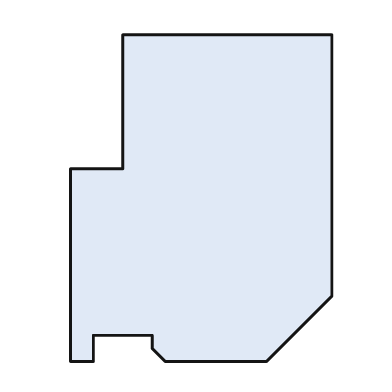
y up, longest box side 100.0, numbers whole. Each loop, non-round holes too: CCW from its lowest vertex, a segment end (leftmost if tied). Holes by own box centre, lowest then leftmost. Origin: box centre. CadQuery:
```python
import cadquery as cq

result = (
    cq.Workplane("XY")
    .moveTo(-40.0, -50.0)
    .lineTo(-33.0, -50.0)
    .lineTo(-33.0, -42.0)
    .lineTo(-15.0, -42.0)
    .lineTo(-15.0, -46.0)
    .lineTo(-11.0, -50.0)
    .lineTo(20.0, -50.0)
    .lineTo(40.0, -30.0)
    .lineTo(40.0, 50.0)
    .lineTo(-24.0, 50.0)
    .lineTo(-24.0, 9.0)
    .lineTo(-40.0, 9.0)
    .close()
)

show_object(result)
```